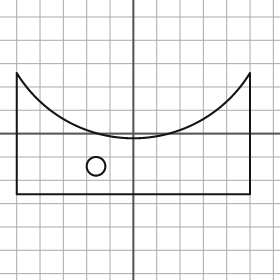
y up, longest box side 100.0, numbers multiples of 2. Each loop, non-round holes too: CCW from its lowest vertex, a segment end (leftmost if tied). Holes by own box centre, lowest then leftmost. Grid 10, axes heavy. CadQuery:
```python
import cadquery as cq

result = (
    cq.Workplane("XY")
    .moveTo(-50.0, -26.0)
    .lineTo(50.0, -26.0)
    .lineTo(50.0, 26.0)
    .threePointArc((0.0, -2.0), (-50.0, 26.0))
    .close()
    .moveTo(-16.0, -14.0)
    .circle(4.0)
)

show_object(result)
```